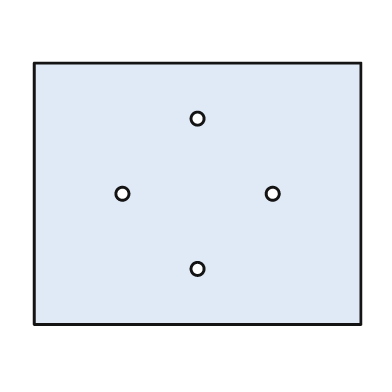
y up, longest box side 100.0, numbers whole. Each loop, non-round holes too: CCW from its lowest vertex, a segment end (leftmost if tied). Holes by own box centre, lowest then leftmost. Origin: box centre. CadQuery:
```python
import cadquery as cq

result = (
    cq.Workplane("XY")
    .moveTo(-50.0, -40.0)
    .lineTo(50.0, -40.0)
    .lineTo(50.0, 40.0)
    .lineTo(-50.0, 40.0)
    .close()
    .moveTo(0.0, -23.0)
    .circle(2.0)
    .moveTo(-23.0, 0.0)
    .circle(2.0)
    .moveTo(23.0, 0.0)
    .circle(2.0)
    .moveTo(0.0, 23.0)
    .circle(2.0)
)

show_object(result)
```